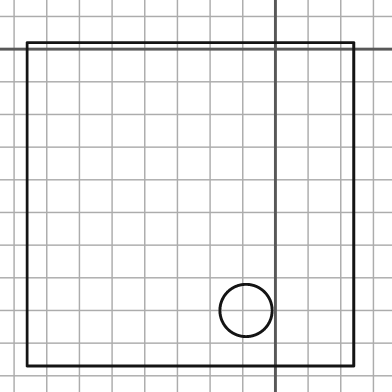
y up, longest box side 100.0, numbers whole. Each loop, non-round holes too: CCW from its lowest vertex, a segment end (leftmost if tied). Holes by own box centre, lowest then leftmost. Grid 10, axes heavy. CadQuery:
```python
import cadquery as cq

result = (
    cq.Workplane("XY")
    .moveTo(-76.0, -97.0)
    .lineTo(24.0, -97.0)
    .lineTo(24.0, 2.0)
    .lineTo(-76.0, 2.0)
    .close()
    .moveTo(-9.0, -80.0)
    .circle(8.0)
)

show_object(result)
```